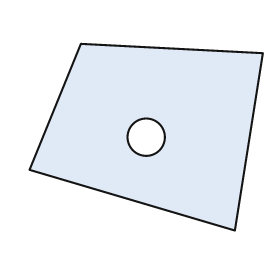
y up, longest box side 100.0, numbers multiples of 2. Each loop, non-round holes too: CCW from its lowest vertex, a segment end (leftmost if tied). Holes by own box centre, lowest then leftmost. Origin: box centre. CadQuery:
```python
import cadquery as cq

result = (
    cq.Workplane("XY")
    .moveTo(38.0, -40.0)
    .lineTo(50.0, 36.0)
    .lineTo(-28.0, 40.0)
    .lineTo(-50.0, -14.0)
    .close()
    .moveTo(0.0, 0.0)
    .circle(8.0)
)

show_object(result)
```